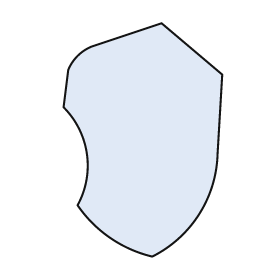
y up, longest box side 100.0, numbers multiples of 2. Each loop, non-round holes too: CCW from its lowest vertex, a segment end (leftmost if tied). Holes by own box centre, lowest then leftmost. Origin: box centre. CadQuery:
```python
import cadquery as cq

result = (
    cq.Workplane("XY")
    .moveTo(4.0, -50.0)
    .threePointArc((24.0, -32.0), (32.0, -6.0))
    .lineTo(34.0, 28.0)
    .lineTo(8.0, 50.0)
    .lineTo(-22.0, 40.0)
    .threePointArc((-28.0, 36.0), (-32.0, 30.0))
    .lineTo(-34.0, 14.0)
    .threePointArc((-24.0, -6.0), (-28.0, -28.0))
    .threePointArc((-14.0, -42.0), (4.0, -50.0))
    .close()
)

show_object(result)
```